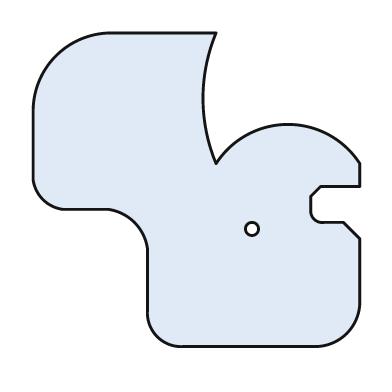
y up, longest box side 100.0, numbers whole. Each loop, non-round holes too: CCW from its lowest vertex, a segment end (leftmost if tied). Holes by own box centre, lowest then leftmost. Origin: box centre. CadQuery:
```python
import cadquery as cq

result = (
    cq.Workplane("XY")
    .moveTo(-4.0, -48.0)
    .lineTo(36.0, -48.0)
    .threePointArc((46.0, -44.0), (50.0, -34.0))
    .lineTo(50.0, -15.0)
    .lineTo(45.0, -10.0)
    .lineTo(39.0, -10.0)
    .threePointArc((36.0, -9.0), (35.0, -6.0))
    .lineTo(35.0, -2.0)
    .lineTo(38.0, 1.0)
    .lineTo(50.0, 1.0)
    .lineTo(50.0, 8.0)
    .threePointArc((28.0, 20.0), (6.0, 8.0))
    .threePointArc((2.0, 28.0), (6.0, 48.0))
    .lineTo(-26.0, 48.0)
    .threePointArc((-43.0, 41.0), (-50.0, 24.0))
    .lineTo(-50.0, 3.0)
    .threePointArc((-47.0, -3.0), (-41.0, -6.0))
    .lineTo(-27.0, -6.0)
    .threePointArc((-19.0, -10.0), (-15.0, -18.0))
    .lineTo(-15.0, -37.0)
    .threePointArc((-12.0, -45.0), (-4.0, -48.0))
    .close()
    .moveTo(17.0, -12.0)
    .circle(2.0)
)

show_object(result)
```